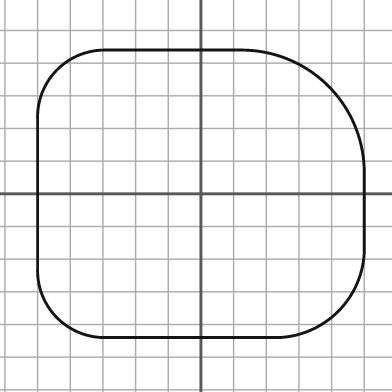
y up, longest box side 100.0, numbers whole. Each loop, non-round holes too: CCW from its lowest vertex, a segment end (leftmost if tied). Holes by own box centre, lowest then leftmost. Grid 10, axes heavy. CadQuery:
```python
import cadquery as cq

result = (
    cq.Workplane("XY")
    .moveTo(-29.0, -44.0)
    .lineTo(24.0, -44.0)
    .threePointArc((42.0, -36.0), (50.0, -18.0))
    .lineTo(50.0, 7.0)
    .threePointArc((39.0, 33.0), (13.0, 44.0))
    .lineTo(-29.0, 44.0)
    .threePointArc((-44.0, 38.0), (-50.0, 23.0))
    .lineTo(-50.0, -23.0)
    .threePointArc((-44.0, -38.0), (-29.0, -44.0))
    .close()
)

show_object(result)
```